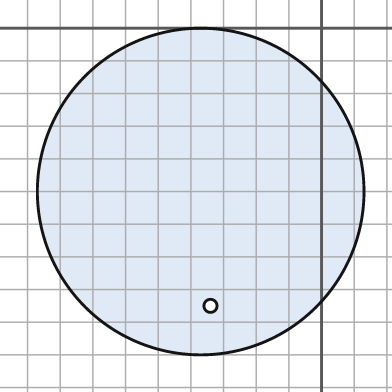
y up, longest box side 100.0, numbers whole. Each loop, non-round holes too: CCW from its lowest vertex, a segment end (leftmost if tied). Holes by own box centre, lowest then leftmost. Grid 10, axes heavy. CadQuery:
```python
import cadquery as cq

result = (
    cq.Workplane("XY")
    .moveTo(-37.0, -50.0)
    .circle(50.0)
    .moveTo(-34.0, -85.0)
    .circle(2.0)
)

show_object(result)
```